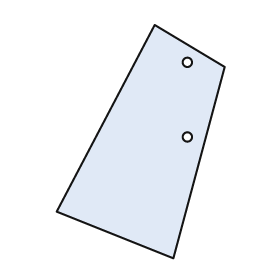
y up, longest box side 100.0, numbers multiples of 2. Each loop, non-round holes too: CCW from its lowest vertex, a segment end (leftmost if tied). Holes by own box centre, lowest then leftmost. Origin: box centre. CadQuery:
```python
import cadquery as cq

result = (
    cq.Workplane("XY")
    .moveTo(14.0, -50.0)
    .lineTo(36.0, 32.0)
    .lineTo(6.0, 50.0)
    .lineTo(-36.0, -30.0)
    .close()
    .moveTo(20.0, 2.0)
    .circle(2.0)
    .moveTo(20.0, 34.0)
    .circle(2.0)
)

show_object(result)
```